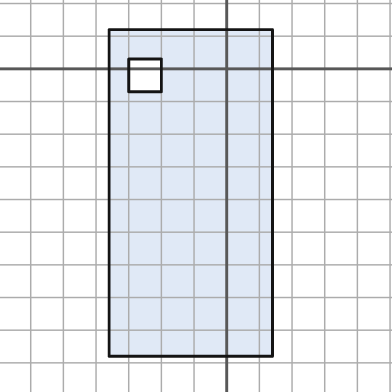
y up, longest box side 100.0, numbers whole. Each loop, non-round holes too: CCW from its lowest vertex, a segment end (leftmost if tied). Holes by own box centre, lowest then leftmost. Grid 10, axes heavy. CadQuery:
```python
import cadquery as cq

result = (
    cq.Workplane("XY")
    .moveTo(-36.0, -88.0)
    .lineTo(14.0, -88.0)
    .lineTo(14.0, 12.0)
    .lineTo(-36.0, 12.0)
    .close()
    .moveTo(-30.0, -7.0)
    .lineTo(-20.0, -7.0)
    .lineTo(-20.0, 3.0)
    .lineTo(-30.0, 3.0)
    .close()
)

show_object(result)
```